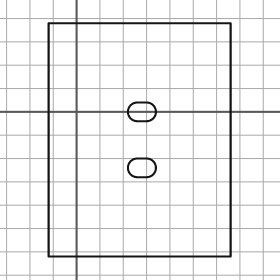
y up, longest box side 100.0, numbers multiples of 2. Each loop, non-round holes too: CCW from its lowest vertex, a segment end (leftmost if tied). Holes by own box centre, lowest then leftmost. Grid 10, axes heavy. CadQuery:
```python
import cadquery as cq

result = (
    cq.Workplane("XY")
    .moveTo(-12.0, -62.0)
    .lineTo(66.0, -62.0)
    .lineTo(66.0, 38.0)
    .lineTo(-12.0, 38.0)
    .close()
    .moveTo(26.0, -28.0)
    .lineTo(30.0, -28.0)
    .threePointArc((34.0, -24.0), (30.0, -20.0))
    .lineTo(26.0, -20.0)
    .threePointArc((22.0, -24.0), (26.0, -28.0))
    .close()
    .moveTo(26.0, -4.0)
    .lineTo(30.0, -4.0)
    .threePointArc((34.0, 0.0), (30.0, 4.0))
    .lineTo(26.0, 4.0)
    .threePointArc((22.0, 0.0), (26.0, -4.0))
    .close()
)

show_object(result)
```